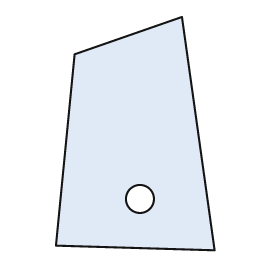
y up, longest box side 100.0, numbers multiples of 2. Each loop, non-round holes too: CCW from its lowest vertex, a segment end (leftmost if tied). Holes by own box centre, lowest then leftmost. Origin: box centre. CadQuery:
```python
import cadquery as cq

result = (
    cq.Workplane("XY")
    .moveTo(34.0, -50.0)
    .lineTo(20.0, 50.0)
    .lineTo(-26.0, 34.0)
    .lineTo(-34.0, -48.0)
    .close()
    .moveTo(2.0, -28.0)
    .circle(6.0)
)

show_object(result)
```